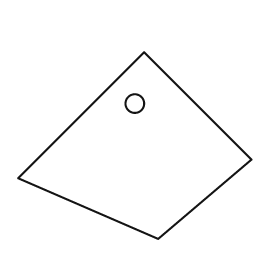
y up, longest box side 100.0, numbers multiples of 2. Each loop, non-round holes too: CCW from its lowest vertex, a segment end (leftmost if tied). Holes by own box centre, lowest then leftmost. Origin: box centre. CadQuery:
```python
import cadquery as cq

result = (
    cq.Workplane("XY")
    .moveTo(10.0, -40.0)
    .lineTo(50.0, -6.0)
    .lineTo(4.0, 40.0)
    .lineTo(-50.0, -14.0)
    .close()
    .moveTo(0.0, 18.0)
    .circle(4.0)
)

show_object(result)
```